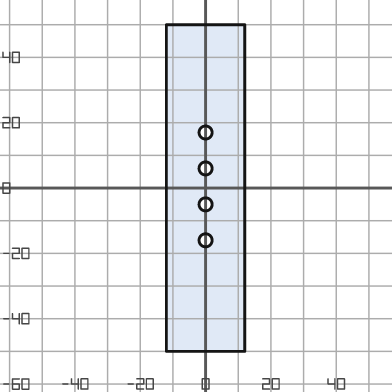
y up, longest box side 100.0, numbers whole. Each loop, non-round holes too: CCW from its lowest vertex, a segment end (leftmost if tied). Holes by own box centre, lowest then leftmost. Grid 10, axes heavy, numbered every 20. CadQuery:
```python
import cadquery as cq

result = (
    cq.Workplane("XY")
    .moveTo(-12.0, -50.0)
    .lineTo(12.0, -50.0)
    .lineTo(12.0, 50.0)
    .lineTo(-12.0, 50.0)
    .close()
    .moveTo(0.0, -16.0)
    .circle(2.0)
    .moveTo(0.0, -5.0)
    .circle(2.0)
    .moveTo(0.0, 6.0)
    .circle(2.0)
    .moveTo(0.0, 17.0)
    .circle(2.0)
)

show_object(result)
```